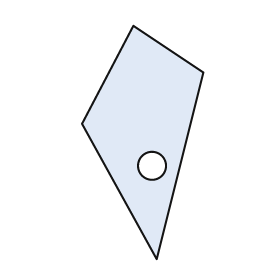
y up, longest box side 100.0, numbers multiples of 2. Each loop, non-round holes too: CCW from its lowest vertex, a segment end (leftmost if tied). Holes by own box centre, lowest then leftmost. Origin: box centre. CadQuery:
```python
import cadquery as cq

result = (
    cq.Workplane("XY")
    .moveTo(6.0, -50.0)
    .lineTo(26.0, 30.0)
    .lineTo(-4.0, 50.0)
    .lineTo(-26.0, 8.0)
    .close()
    .moveTo(4.0, -10.0)
    .circle(6.0)
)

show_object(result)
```